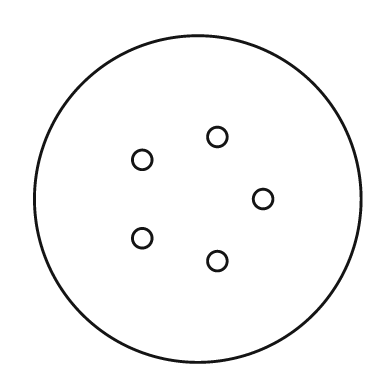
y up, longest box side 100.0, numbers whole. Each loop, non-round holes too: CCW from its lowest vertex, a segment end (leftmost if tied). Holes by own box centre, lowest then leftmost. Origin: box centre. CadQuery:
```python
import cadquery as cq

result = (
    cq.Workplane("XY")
    .moveTo(0.0, 0.0)
    .circle(50.0)
    .moveTo(6.0, -19.0)
    .circle(3.0)
    .moveTo(-17.0, -12.0)
    .circle(3.0)
    .moveTo(20.0, 0.0)
    .circle(3.0)
    .moveTo(-17.0, 12.0)
    .circle(3.0)
    .moveTo(6.0, 19.0)
    .circle(3.0)
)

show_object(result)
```